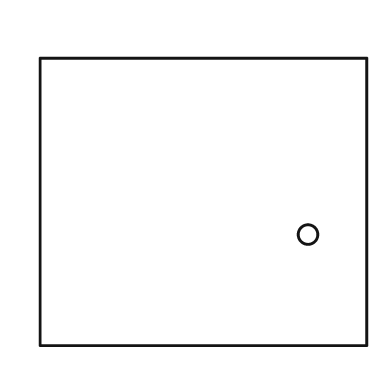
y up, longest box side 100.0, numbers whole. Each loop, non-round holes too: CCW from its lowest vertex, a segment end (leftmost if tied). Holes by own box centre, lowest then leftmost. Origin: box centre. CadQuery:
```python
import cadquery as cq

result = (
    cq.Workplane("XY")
    .moveTo(-50.0, -44.0)
    .lineTo(50.0, -44.0)
    .lineTo(50.0, 44.0)
    .lineTo(-50.0, 44.0)
    .close()
    .moveTo(32.0, -10.0)
    .circle(3.0)
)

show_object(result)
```